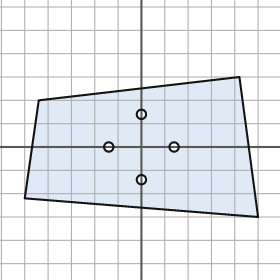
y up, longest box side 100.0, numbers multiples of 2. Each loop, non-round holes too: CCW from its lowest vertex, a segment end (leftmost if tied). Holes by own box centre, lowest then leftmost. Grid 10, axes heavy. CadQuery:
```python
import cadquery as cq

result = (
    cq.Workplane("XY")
    .moveTo(50.0, -30.0)
    .lineTo(42.0, 30.0)
    .lineTo(-44.0, 20.0)
    .lineTo(-50.0, -22.0)
    .close()
    .moveTo(0.0, -14.0)
    .circle(2.0)
    .moveTo(-14.0, 0.0)
    .circle(2.0)
    .moveTo(14.0, 0.0)
    .circle(2.0)
    .moveTo(0.0, 14.0)
    .circle(2.0)
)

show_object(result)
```